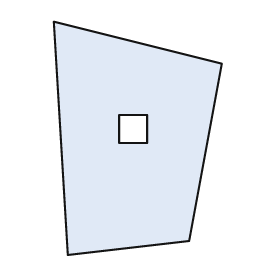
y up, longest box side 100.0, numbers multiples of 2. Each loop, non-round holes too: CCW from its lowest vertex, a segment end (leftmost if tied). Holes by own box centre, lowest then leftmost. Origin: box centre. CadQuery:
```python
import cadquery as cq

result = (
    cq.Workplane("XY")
    .moveTo(-30.0, -50.0)
    .lineTo(22.0, -44.0)
    .lineTo(36.0, 32.0)
    .lineTo(-36.0, 50.0)
    .close()
    .moveTo(-8.0, -2.0)
    .lineTo(4.0, -2.0)
    .lineTo(4.0, 10.0)
    .lineTo(-8.0, 10.0)
    .close()
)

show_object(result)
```